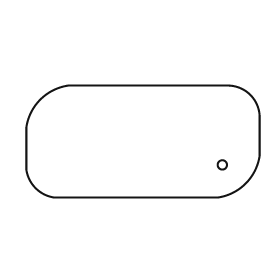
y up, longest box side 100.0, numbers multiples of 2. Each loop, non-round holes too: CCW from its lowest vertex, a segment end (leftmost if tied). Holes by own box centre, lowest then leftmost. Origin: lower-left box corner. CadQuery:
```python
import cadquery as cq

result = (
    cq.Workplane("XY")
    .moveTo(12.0, 0.0)
    .lineTo(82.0, 0.0)
    .threePointArc((94.0, 6.0), (100.0, 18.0))
    .lineTo(100.0, 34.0)
    .threePointArc((96.0, 44.0), (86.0, 48.0))
    .lineTo(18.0, 48.0)
    .threePointArc((6.0, 42.0), (0.0, 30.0))
    .lineTo(0.0, 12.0)
    .threePointArc((4.0, 4.0), (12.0, 0.0))
    .close()
    .moveTo(84.0, 14.0)
    .circle(2.0)
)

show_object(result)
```